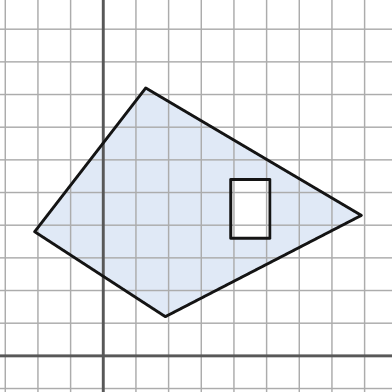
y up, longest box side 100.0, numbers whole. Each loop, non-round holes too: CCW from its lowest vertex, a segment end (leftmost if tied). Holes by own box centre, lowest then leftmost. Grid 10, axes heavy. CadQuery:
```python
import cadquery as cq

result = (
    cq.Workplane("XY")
    .moveTo(19.0, 12.0)
    .lineTo(79.0, 43.0)
    .lineTo(13.0, 82.0)
    .lineTo(-21.0, 38.0)
    .close()
    .moveTo(39.0, 36.0)
    .lineTo(51.0, 36.0)
    .lineTo(51.0, 54.0)
    .lineTo(39.0, 54.0)
    .close()
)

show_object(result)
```